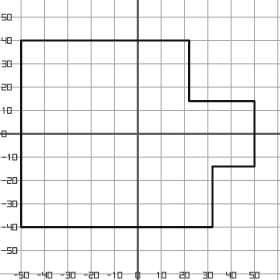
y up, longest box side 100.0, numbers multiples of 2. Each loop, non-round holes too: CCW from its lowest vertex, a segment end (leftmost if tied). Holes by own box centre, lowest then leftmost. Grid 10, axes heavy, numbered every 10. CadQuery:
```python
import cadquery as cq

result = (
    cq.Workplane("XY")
    .moveTo(-50.0, -40.0)
    .lineTo(32.0, -40.0)
    .lineTo(32.0, -14.0)
    .lineTo(50.0, -14.0)
    .lineTo(50.0, 14.0)
    .lineTo(22.0, 14.0)
    .lineTo(22.0, 40.0)
    .lineTo(-50.0, 40.0)
    .close()
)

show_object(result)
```